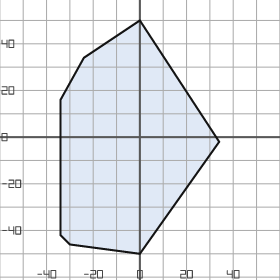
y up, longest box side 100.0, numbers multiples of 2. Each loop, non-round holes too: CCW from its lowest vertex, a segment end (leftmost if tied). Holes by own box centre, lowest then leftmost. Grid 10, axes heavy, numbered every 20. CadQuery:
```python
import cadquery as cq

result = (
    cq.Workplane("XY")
    .moveTo(0.0, -50.0)
    .lineTo(34.0, -2.0)
    .lineTo(0.0, 50.0)
    .lineTo(-24.0, 34.0)
    .lineTo(-34.0, 16.0)
    .lineTo(-34.0, -42.0)
    .lineTo(-30.0, -46.0)
    .close()
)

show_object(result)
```